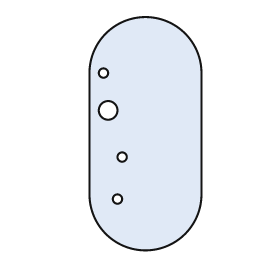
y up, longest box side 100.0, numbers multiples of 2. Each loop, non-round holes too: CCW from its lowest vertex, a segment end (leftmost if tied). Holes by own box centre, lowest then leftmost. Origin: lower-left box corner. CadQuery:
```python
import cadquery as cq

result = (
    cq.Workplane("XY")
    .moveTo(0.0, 24.0)
    .threePointArc((24.0, 0.0), (48.0, 24.0))
    .lineTo(48.0, 76.0)
    .threePointArc((24.0, 100.0), (0.0, 76.0))
    .close()
    .moveTo(12.0, 22.0)
    .circle(2.0)
    .moveTo(14.0, 40.0)
    .circle(2.0)
    .moveTo(8.0, 60.0)
    .circle(4.0)
    .moveTo(6.0, 76.0)
    .circle(2.0)
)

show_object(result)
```